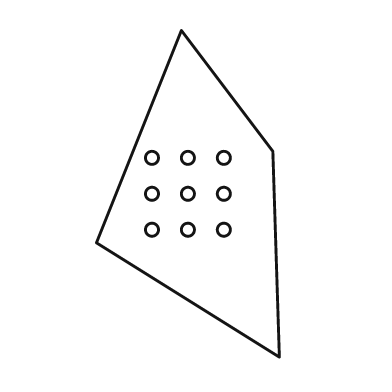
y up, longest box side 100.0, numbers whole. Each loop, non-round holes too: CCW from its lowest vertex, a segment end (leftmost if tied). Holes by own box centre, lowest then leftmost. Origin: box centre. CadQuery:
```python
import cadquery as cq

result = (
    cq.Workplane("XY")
    .moveTo(28.0, -50.0)
    .lineTo(26.0, 13.0)
    .lineTo(-2.0, 50.0)
    .lineTo(-28.0, -15.0)
    .close()
    .moveTo(-11.0, -11.0)
    .circle(2.0)
    .moveTo(0.0, -11.0)
    .circle(2.0)
    .moveTo(11.0, -11.0)
    .circle(2.0)
    .moveTo(-11.0, 0.0)
    .circle(2.0)
    .moveTo(0.0, 0.0)
    .circle(2.0)
    .moveTo(11.0, 0.0)
    .circle(2.0)
    .moveTo(-11.0, 11.0)
    .circle(2.0)
    .moveTo(0.0, 11.0)
    .circle(2.0)
    .moveTo(11.0, 11.0)
    .circle(2.0)
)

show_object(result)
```